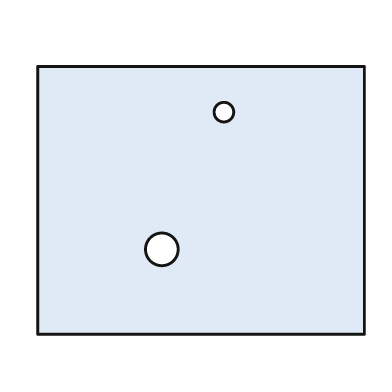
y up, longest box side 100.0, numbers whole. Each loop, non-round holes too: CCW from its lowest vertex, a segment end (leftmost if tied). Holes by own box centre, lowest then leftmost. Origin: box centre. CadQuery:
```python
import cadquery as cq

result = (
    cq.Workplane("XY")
    .moveTo(-50.0, -41.0)
    .lineTo(50.0, -41.0)
    .lineTo(50.0, 41.0)
    .lineTo(-50.0, 41.0)
    .close()
    .moveTo(-12.0, -15.0)
    .circle(5.0)
    .moveTo(7.0, 27.0)
    .circle(3.0)
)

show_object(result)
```